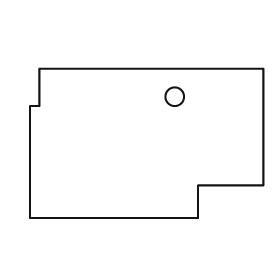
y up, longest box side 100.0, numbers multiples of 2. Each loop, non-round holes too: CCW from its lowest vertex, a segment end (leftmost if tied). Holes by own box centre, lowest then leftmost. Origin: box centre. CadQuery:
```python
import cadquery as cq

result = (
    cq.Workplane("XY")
    .moveTo(-50.0, -32.0)
    .lineTo(22.0, -32.0)
    .lineTo(22.0, -18.0)
    .lineTo(50.0, -18.0)
    .lineTo(50.0, 32.0)
    .lineTo(-46.0, 32.0)
    .lineTo(-46.0, 16.0)
    .lineTo(-50.0, 16.0)
    .close()
    .moveTo(12.0, 20.0)
    .circle(4.0)
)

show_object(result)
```